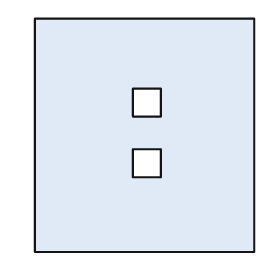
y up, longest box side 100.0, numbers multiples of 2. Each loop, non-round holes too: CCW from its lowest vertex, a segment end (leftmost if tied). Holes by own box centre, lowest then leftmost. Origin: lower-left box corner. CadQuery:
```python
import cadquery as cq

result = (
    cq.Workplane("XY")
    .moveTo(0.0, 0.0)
    .lineTo(94.0, 0.0)
    .lineTo(94.0, 100.0)
    .lineTo(0.0, 100.0)
    .close()
    .moveTo(42.0, 32.0)
    .lineTo(54.0, 32.0)
    .lineTo(54.0, 44.0)
    .lineTo(42.0, 44.0)
    .close()
    .moveTo(42.0, 58.0)
    .lineTo(54.0, 58.0)
    .lineTo(54.0, 70.0)
    .lineTo(42.0, 70.0)
    .close()
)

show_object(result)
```